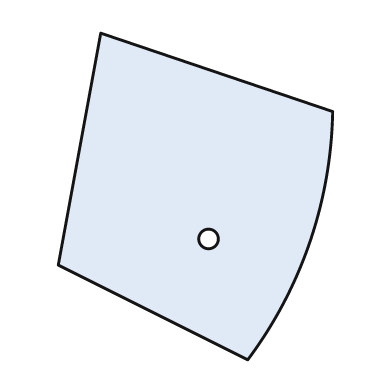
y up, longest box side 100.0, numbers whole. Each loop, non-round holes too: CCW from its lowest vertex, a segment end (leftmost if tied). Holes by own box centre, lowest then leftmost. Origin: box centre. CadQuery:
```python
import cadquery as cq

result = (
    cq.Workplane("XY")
    .moveTo(16.0, -50.0)
    .threePointArc((35.0, -14.0), (42.0, 26.0))
    .lineTo(-29.0, 50.0)
    .lineTo(-42.0, -21.0)
    .close()
    .moveTo(4.0, -13.0)
    .circle(3.0)
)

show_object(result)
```